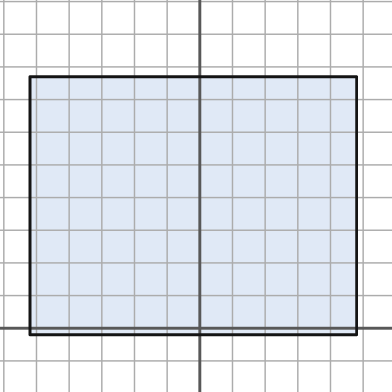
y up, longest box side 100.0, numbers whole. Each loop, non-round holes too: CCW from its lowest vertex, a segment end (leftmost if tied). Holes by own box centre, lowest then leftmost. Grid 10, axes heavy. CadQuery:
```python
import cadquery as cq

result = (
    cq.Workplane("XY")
    .moveTo(-52.0, -2.0)
    .lineTo(48.0, -2.0)
    .lineTo(48.0, 77.0)
    .lineTo(-52.0, 77.0)
    .close()
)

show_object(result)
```